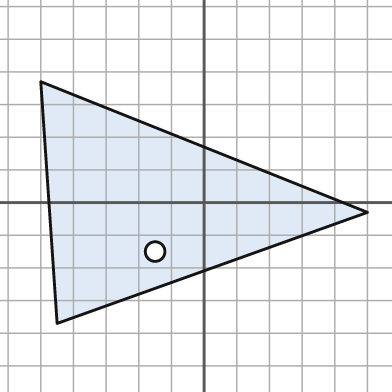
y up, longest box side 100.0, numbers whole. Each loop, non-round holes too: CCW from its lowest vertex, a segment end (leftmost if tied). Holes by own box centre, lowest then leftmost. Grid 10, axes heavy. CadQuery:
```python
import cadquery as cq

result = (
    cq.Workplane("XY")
    .moveTo(-45.0, -37.0)
    .lineTo(50.0, -3.0)
    .lineTo(-50.0, 37.0)
    .close()
    .moveTo(-15.0, -15.0)
    .circle(3.0)
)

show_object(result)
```